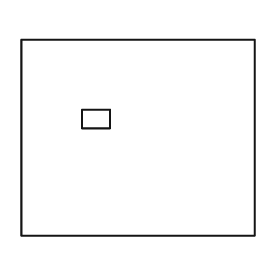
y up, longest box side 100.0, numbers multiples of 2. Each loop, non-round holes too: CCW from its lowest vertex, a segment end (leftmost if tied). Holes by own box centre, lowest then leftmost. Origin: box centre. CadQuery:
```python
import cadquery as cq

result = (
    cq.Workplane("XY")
    .moveTo(-50.0, -42.0)
    .lineTo(50.0, -42.0)
    .lineTo(50.0, 42.0)
    .lineTo(-50.0, 42.0)
    .close()
    .moveTo(-24.0, 4.0)
    .lineTo(-12.0, 4.0)
    .lineTo(-12.0, 12.0)
    .lineTo(-24.0, 12.0)
    .close()
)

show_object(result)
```